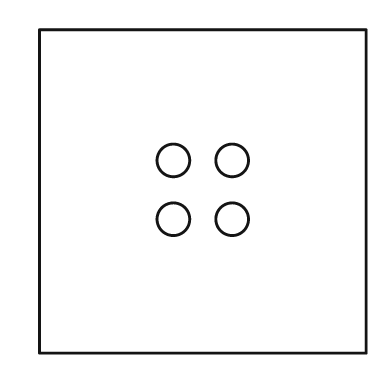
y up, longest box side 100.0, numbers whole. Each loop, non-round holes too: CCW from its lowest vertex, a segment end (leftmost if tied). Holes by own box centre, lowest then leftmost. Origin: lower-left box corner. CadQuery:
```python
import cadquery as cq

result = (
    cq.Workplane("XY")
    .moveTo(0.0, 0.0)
    .lineTo(100.0, 0.0)
    .lineTo(100.0, 99.0)
    .lineTo(0.0, 99.0)
    .close()
    .moveTo(41.0, 41.0)
    .circle(5.0)
    .moveTo(59.0, 41.0)
    .circle(5.0)
    .moveTo(41.0, 59.0)
    .circle(5.0)
    .moveTo(59.0, 59.0)
    .circle(5.0)
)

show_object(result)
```